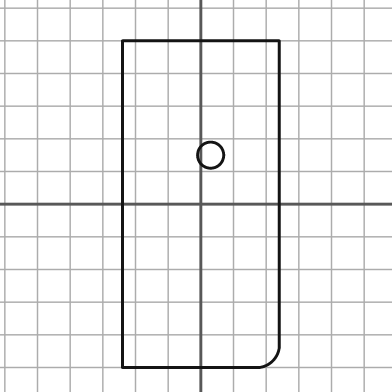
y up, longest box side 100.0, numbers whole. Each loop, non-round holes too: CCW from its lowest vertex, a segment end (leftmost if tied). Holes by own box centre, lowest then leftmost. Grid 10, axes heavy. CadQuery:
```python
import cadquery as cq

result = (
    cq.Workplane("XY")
    .moveTo(-24.0, -50.0)
    .lineTo(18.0, -50.0)
    .threePointArc((22.0, -48.0), (24.0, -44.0))
    .lineTo(24.0, 50.0)
    .lineTo(-24.0, 50.0)
    .close()
    .moveTo(3.0, 15.0)
    .circle(4.0)
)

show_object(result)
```